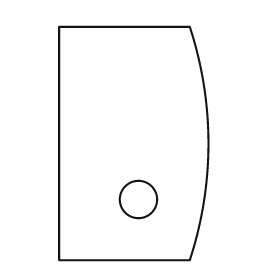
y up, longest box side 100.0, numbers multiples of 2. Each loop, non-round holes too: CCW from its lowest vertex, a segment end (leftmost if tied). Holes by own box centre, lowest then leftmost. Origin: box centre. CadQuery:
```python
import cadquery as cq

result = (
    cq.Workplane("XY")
    .moveTo(-32.0, -50.0)
    .lineTo(24.0, -50.0)
    .threePointArc((32.0, 0.0), (24.0, 50.0))
    .lineTo(-32.0, 50.0)
    .close()
    .moveTo(2.0, -24.0)
    .circle(8.0)
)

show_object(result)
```